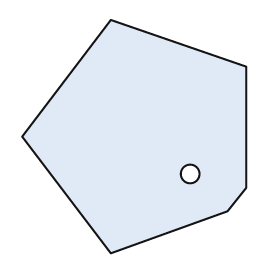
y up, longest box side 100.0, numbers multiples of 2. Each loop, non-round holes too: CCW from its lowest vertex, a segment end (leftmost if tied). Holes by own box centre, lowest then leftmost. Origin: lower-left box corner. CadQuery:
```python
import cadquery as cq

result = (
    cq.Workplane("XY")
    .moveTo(38.0, 0.0)
    .lineTo(88.0, 18.0)
    .lineTo(96.0, 28.0)
    .lineTo(96.0, 80.0)
    .lineTo(38.0, 100.0)
    .lineTo(0.0, 50.0)
    .close()
    .moveTo(72.0, 34.0)
    .circle(4.0)
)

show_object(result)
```